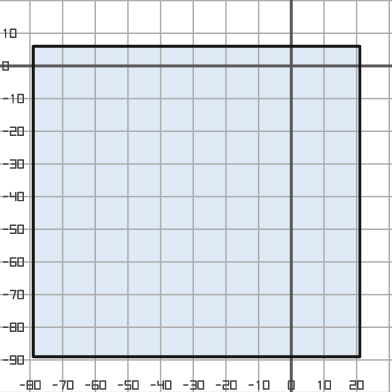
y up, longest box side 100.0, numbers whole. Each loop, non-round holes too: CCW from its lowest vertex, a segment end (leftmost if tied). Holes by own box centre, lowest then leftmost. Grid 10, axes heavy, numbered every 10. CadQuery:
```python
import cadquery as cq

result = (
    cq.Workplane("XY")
    .moveTo(-79.0, -89.0)
    .lineTo(21.0, -89.0)
    .lineTo(21.0, 6.0)
    .lineTo(-79.0, 6.0)
    .close()
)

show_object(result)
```